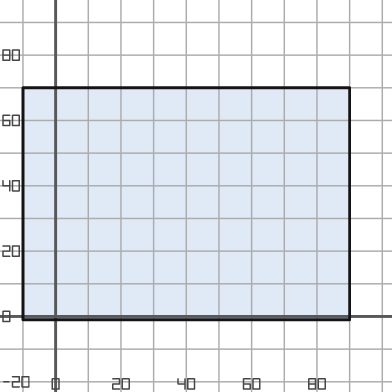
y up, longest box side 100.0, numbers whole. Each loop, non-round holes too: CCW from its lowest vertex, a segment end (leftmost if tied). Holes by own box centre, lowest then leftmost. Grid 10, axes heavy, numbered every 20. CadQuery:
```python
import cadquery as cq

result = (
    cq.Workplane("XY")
    .moveTo(-10.0, -1.0)
    .lineTo(90.0, -1.0)
    .lineTo(90.0, 70.0)
    .lineTo(-10.0, 70.0)
    .close()
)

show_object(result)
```